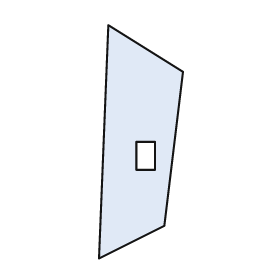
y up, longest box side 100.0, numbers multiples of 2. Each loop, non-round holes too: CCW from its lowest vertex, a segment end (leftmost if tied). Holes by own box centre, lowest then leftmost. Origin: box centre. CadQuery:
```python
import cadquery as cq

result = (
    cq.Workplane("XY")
    .moveTo(-18.0, -50.0)
    .lineTo(10.0, -36.0)
    .lineTo(18.0, 30.0)
    .lineTo(-14.0, 50.0)
    .close()
    .moveTo(-2.0, -12.0)
    .lineTo(6.0, -12.0)
    .lineTo(6.0, 0.0)
    .lineTo(-2.0, 0.0)
    .close()
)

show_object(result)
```